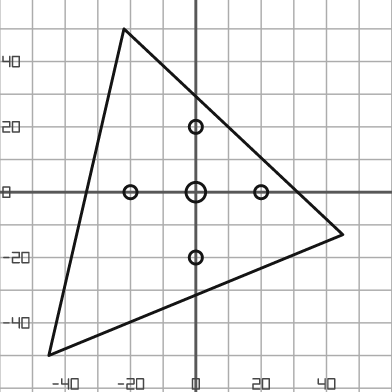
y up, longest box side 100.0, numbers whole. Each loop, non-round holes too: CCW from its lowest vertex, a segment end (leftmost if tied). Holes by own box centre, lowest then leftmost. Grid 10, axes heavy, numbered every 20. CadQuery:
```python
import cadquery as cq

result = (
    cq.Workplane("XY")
    .moveTo(-45.0, -50.0)
    .lineTo(45.0, -13.0)
    .lineTo(-22.0, 50.0)
    .close()
    .moveTo(0.0, -20.0)
    .circle(2.0)
    .moveTo(-20.0, 0.0)
    .circle(2.0)
    .moveTo(0.0, 0.0)
    .circle(3.0)
    .moveTo(20.0, 0.0)
    .circle(2.0)
    .moveTo(0.0, 20.0)
    .circle(2.0)
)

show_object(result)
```